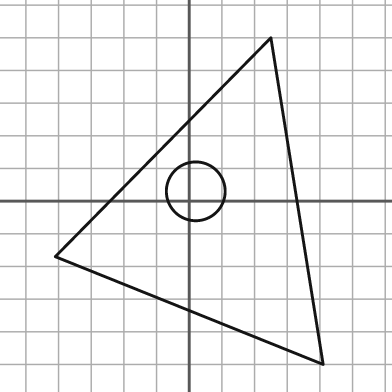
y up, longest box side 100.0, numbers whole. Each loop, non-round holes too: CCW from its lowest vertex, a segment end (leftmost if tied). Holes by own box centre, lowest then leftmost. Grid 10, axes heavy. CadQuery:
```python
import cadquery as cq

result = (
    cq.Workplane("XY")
    .moveTo(41.0, -50.0)
    .lineTo(25.0, 50.0)
    .lineTo(-41.0, -17.0)
    .close()
    .moveTo(2.0, 3.0)
    .circle(9.0)
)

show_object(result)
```